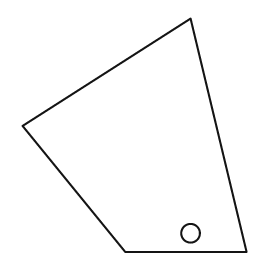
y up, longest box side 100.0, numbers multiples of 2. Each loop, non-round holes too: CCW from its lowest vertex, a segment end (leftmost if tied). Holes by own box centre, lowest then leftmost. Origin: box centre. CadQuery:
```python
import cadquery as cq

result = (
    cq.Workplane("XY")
    .moveTo(-4.0, -50.0)
    .lineTo(48.0, -50.0)
    .lineTo(24.0, 50.0)
    .lineTo(-48.0, 4.0)
    .close()
    .moveTo(24.0, -42.0)
    .circle(4.0)
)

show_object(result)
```